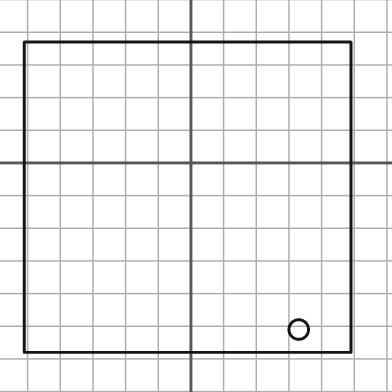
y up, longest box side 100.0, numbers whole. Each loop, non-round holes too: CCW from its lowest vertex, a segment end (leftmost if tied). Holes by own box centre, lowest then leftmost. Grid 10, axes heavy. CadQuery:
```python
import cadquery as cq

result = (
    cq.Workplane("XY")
    .moveTo(-51.0, -58.0)
    .lineTo(49.0, -58.0)
    .lineTo(49.0, 37.0)
    .lineTo(-51.0, 37.0)
    .close()
    .moveTo(33.0, -51.0)
    .circle(3.0)
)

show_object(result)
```